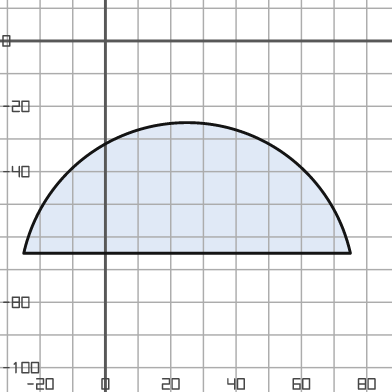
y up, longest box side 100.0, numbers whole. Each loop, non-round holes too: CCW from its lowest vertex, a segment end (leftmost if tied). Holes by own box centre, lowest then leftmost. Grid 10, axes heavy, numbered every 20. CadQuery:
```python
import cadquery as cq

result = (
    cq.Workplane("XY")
    .moveTo(-25.0, -65.0)
    .lineTo(75.0, -65.0)
    .threePointArc((25.0, -25.0), (-25.0, -65.0))
    .close()
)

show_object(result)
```